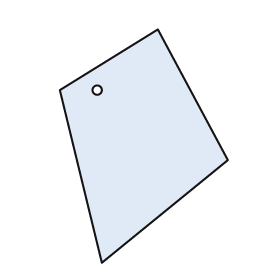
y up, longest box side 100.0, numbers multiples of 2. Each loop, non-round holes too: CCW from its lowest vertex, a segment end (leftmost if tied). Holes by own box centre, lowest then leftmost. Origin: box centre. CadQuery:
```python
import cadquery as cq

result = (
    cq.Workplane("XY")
    .moveTo(-18.0, -50.0)
    .lineTo(36.0, -6.0)
    .lineTo(6.0, 50.0)
    .lineTo(-36.0, 24.0)
    .close()
    .moveTo(-20.0, 24.0)
    .circle(2.0)
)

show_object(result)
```